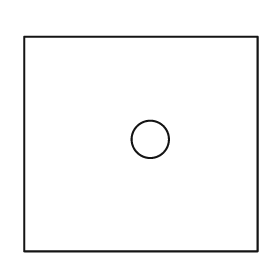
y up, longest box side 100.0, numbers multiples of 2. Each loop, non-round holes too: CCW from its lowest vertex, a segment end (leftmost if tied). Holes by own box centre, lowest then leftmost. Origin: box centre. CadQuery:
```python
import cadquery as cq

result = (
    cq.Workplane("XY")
    .moveTo(-50.0, -46.0)
    .lineTo(50.0, -46.0)
    .lineTo(50.0, 46.0)
    .lineTo(-50.0, 46.0)
    .close()
    .moveTo(4.0, 2.0)
    .circle(8.0)
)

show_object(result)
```